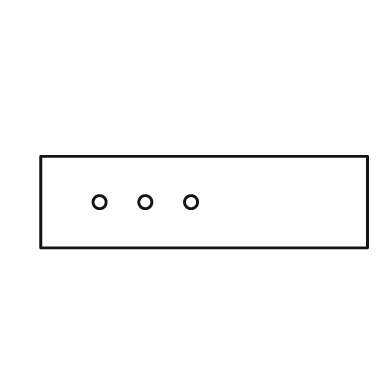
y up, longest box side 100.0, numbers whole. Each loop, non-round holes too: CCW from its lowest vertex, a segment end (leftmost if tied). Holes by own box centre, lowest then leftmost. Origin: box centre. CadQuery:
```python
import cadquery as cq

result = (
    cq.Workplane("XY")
    .moveTo(-50.0, -14.0)
    .lineTo(50.0, -14.0)
    .lineTo(50.0, 14.0)
    .lineTo(-50.0, 14.0)
    .close()
    .moveTo(-32.0, 0.0)
    .circle(2.0)
    .moveTo(-18.0, 0.0)
    .circle(2.0)
    .moveTo(-4.0, 0.0)
    .circle(2.0)
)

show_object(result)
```